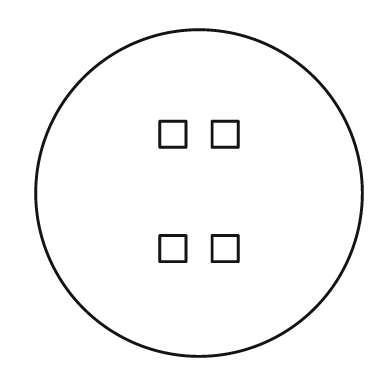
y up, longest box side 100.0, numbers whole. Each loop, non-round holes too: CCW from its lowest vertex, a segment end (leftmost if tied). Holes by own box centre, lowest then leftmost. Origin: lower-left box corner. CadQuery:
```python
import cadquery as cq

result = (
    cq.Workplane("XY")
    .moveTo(50.0, 50.0)
    .circle(50.0)
    .moveTo(38.0, 29.0)
    .lineTo(46.0, 29.0)
    .lineTo(46.0, 37.0)
    .lineTo(38.0, 37.0)
    .close()
    .moveTo(54.0, 29.0)
    .lineTo(62.0, 29.0)
    .lineTo(62.0, 37.0)
    .lineTo(54.0, 37.0)
    .close()
    .moveTo(38.0, 64.0)
    .lineTo(46.0, 64.0)
    .lineTo(46.0, 72.0)
    .lineTo(38.0, 72.0)
    .close()
    .moveTo(54.0, 64.0)
    .lineTo(62.0, 64.0)
    .lineTo(62.0, 72.0)
    .lineTo(54.0, 72.0)
    .close()
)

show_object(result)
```